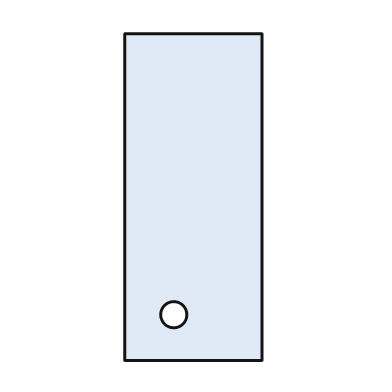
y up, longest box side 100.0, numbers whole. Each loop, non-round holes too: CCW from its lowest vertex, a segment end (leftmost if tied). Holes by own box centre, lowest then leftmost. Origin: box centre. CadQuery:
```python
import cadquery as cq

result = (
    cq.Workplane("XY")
    .moveTo(-21.0, -50.0)
    .lineTo(21.0, -50.0)
    .lineTo(21.0, 50.0)
    .lineTo(-21.0, 50.0)
    .close()
    .moveTo(-6.0, -36.0)
    .circle(4.0)
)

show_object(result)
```